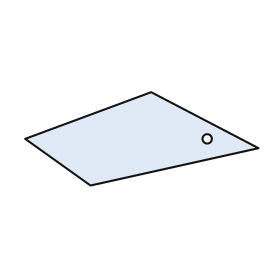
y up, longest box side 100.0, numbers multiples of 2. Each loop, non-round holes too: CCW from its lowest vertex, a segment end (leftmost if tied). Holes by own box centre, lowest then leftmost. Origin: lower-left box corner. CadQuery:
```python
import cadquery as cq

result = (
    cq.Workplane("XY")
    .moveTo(28.0, 0.0)
    .lineTo(100.0, 16.0)
    .lineTo(54.0, 40.0)
    .lineTo(0.0, 20.0)
    .close()
    .moveTo(78.0, 20.0)
    .circle(2.0)
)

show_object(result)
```